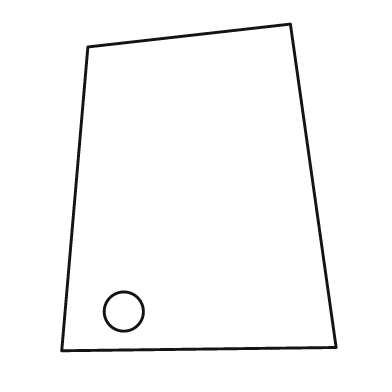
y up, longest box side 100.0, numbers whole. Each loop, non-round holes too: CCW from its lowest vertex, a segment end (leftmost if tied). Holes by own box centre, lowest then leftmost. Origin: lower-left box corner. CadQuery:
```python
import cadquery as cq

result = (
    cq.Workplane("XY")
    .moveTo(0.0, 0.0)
    .lineTo(84.0, 1.0)
    .lineTo(70.0, 100.0)
    .lineTo(8.0, 93.0)
    .close()
    .moveTo(19.0, 12.0)
    .circle(6.0)
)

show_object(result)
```